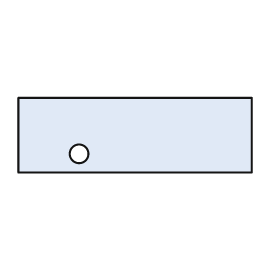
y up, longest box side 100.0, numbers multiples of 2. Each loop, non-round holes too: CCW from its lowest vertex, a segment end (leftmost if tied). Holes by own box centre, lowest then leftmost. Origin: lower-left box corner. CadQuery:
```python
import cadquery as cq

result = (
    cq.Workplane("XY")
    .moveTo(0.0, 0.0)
    .lineTo(100.0, 0.0)
    .lineTo(100.0, 32.0)
    .lineTo(0.0, 32.0)
    .close()
    .moveTo(26.0, 8.0)
    .circle(4.0)
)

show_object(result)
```